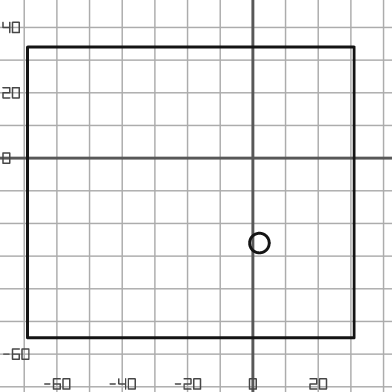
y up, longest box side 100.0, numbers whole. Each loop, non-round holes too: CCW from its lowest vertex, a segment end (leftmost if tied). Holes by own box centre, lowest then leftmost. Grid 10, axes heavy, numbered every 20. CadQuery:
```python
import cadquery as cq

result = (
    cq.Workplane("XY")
    .moveTo(-69.0, -55.0)
    .lineTo(31.0, -55.0)
    .lineTo(31.0, 34.0)
    .lineTo(-69.0, 34.0)
    .close()
    .moveTo(2.0, -26.0)
    .circle(3.0)
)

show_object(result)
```